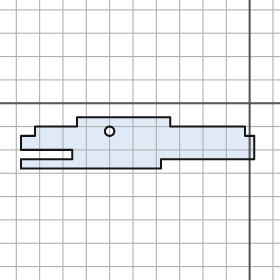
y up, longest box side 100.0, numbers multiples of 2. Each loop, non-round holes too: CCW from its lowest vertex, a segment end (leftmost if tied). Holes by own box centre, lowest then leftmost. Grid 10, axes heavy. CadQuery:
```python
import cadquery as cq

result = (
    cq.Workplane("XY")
    .moveTo(-98.0, -28.0)
    .lineTo(-38.0, -28.0)
    .lineTo(-38.0, -24.0)
    .lineTo(2.0, -24.0)
    .lineTo(2.0, -14.0)
    .lineTo(-2.0, -14.0)
    .lineTo(-2.0, -10.0)
    .lineTo(-34.0, -10.0)
    .lineTo(-34.0, -6.0)
    .lineTo(-74.0, -6.0)
    .lineTo(-74.0, -10.0)
    .lineTo(-92.0, -10.0)
    .lineTo(-92.0, -14.0)
    .lineTo(-98.0, -14.0)
    .lineTo(-98.0, -20.0)
    .lineTo(-76.0, -20.0)
    .lineTo(-76.0, -24.0)
    .lineTo(-98.0, -24.0)
    .close()
    .moveTo(-60.0, -12.0)
    .circle(2.0)
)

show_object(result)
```